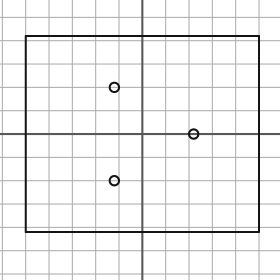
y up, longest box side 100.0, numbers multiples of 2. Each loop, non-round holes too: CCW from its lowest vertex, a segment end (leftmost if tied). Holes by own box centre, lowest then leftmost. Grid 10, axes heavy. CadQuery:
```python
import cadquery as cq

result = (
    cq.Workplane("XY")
    .moveTo(-50.0, -42.0)
    .lineTo(50.0, -42.0)
    .lineTo(50.0, 42.0)
    .lineTo(-50.0, 42.0)
    .close()
    .moveTo(-12.0, -20.0)
    .circle(2.0)
    .moveTo(22.0, 0.0)
    .circle(2.0)
    .moveTo(-12.0, 20.0)
    .circle(2.0)
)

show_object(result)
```